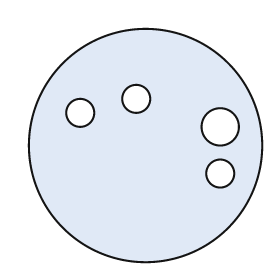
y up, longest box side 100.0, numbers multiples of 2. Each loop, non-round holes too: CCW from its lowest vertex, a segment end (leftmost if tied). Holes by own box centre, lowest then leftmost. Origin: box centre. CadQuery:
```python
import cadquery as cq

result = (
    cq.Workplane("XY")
    .moveTo(0.0, 0.0)
    .circle(50.0)
    .moveTo(32.0, -12.0)
    .circle(6.0)
    .moveTo(32.0, 8.0)
    .circle(8.0)
    .moveTo(-28.0, 14.0)
    .circle(6.0)
    .moveTo(-4.0, 20.0)
    .circle(6.0)
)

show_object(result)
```